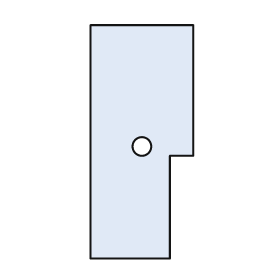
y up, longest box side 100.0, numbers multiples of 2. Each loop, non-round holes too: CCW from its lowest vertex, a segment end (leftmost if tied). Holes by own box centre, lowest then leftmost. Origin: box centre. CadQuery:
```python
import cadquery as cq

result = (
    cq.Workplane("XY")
    .moveTo(-22.0, -50.0)
    .lineTo(12.0, -50.0)
    .lineTo(12.0, -6.0)
    .lineTo(22.0, -6.0)
    .lineTo(22.0, 50.0)
    .lineTo(-22.0, 50.0)
    .close()
    .moveTo(0.0, -2.0)
    .circle(4.0)
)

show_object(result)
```